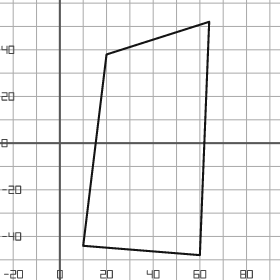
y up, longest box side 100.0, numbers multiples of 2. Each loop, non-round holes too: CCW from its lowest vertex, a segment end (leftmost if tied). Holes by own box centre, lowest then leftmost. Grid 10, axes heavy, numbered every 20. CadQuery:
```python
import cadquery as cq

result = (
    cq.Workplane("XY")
    .moveTo(60.0, -48.0)
    .lineTo(64.0, 52.0)
    .lineTo(20.0, 38.0)
    .lineTo(10.0, -44.0)
    .close()
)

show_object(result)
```